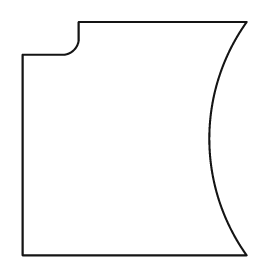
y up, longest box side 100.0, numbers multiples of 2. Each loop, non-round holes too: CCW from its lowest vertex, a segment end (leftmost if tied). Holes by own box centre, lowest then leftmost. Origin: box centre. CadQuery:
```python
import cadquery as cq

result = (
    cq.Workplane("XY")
    .moveTo(-48.0, -50.0)
    .lineTo(48.0, -50.0)
    .threePointArc((32.0, 0.0), (48.0, 50.0))
    .lineTo(-24.0, 50.0)
    .lineTo(-24.0, 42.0)
    .threePointArc((-26.0, 38.0), (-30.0, 36.0))
    .lineTo(-48.0, 36.0)
    .close()
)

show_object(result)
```